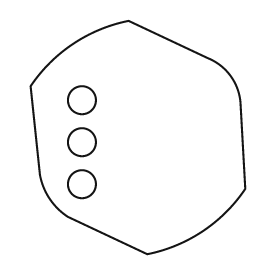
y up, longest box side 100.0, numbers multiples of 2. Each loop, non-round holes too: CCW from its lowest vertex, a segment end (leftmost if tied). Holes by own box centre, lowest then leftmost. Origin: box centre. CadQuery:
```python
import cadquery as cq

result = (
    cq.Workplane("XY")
    .moveTo(4.0, -50.0)
    .threePointArc((28.0, -40.0), (46.0, -22.0))
    .lineTo(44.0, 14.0)
    .threePointArc((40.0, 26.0), (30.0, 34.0))
    .lineTo(-4.0, 50.0)
    .threePointArc((-28.0, 40.0), (-46.0, 22.0))
    .lineTo(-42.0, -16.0)
    .threePointArc((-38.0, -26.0), (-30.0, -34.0))
    .close()
    .moveTo(-24.0, -20.0)
    .circle(6.0)
    .moveTo(-24.0, -2.0)
    .circle(6.0)
    .moveTo(-24.0, 16.0)
    .circle(6.0)
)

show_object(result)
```